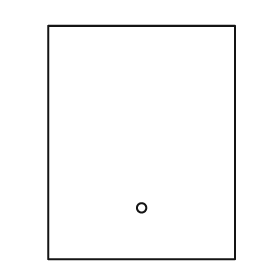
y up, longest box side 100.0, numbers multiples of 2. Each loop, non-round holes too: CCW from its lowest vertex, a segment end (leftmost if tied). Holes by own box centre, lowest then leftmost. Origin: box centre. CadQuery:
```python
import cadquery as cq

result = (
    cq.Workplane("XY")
    .moveTo(-40.0, -50.0)
    .lineTo(40.0, -50.0)
    .lineTo(40.0, 50.0)
    .lineTo(-40.0, 50.0)
    .close()
    .moveTo(0.0, -28.0)
    .circle(2.0)
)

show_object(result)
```